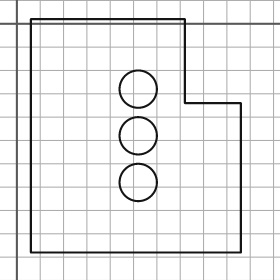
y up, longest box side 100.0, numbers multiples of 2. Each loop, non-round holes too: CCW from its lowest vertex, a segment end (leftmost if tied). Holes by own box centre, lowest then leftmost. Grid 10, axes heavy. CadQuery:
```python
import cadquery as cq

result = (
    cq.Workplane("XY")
    .moveTo(6.0, -98.0)
    .lineTo(96.0, -98.0)
    .lineTo(96.0, -34.0)
    .lineTo(72.0, -34.0)
    .lineTo(72.0, 2.0)
    .lineTo(6.0, 2.0)
    .close()
    .moveTo(52.0, -68.0)
    .circle(8.0)
    .moveTo(52.0, -48.0)
    .circle(8.0)
    .moveTo(52.0, -28.0)
    .circle(8.0)
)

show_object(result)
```